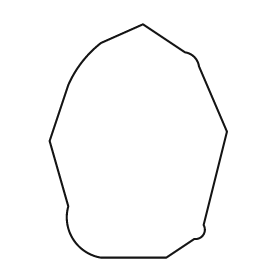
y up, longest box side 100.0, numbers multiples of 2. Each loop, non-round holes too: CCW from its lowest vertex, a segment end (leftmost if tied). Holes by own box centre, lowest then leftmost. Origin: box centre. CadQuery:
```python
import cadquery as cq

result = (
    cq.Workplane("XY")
    .moveTo(-16.0, -50.0)
    .lineTo(12.0, -50.0)
    .lineTo(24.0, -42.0)
    .threePointArc((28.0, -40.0), (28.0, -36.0))
    .lineTo(38.0, 4.0)
    .lineTo(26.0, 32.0)
    .threePointArc((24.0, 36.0), (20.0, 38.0))
    .lineTo(2.0, 50.0)
    .lineTo(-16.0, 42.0)
    .threePointArc((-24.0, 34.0), (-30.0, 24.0))
    .lineTo(-38.0, 0.0)
    .lineTo(-30.0, -28.0)
    .threePointArc((-28.0, -42.0), (-16.0, -50.0))
    .close()
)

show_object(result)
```